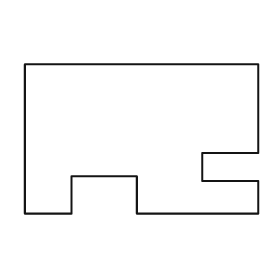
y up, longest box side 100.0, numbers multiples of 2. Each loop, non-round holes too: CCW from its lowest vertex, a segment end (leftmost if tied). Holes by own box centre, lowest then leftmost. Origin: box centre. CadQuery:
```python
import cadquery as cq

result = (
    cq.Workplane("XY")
    .moveTo(-50.0, -32.0)
    .lineTo(-30.0, -32.0)
    .lineTo(-30.0, -16.0)
    .lineTo(-2.0, -16.0)
    .lineTo(-2.0, -32.0)
    .lineTo(50.0, -32.0)
    .lineTo(50.0, -18.0)
    .lineTo(26.0, -18.0)
    .lineTo(26.0, -6.0)
    .lineTo(50.0, -6.0)
    .lineTo(50.0, 32.0)
    .lineTo(-50.0, 32.0)
    .close()
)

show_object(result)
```